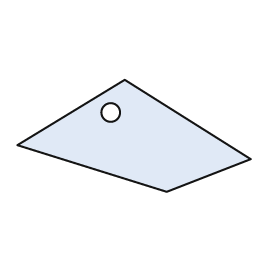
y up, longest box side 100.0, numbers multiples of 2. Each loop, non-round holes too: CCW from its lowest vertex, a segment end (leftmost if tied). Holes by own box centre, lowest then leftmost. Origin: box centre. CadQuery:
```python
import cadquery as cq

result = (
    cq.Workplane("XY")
    .moveTo(14.0, -24.0)
    .lineTo(50.0, -10.0)
    .lineTo(-4.0, 24.0)
    .lineTo(-50.0, -4.0)
    .close()
    .moveTo(-10.0, 10.0)
    .circle(4.0)
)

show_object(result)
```